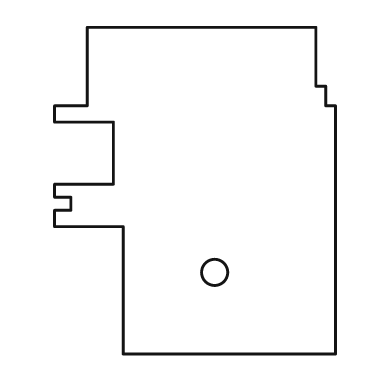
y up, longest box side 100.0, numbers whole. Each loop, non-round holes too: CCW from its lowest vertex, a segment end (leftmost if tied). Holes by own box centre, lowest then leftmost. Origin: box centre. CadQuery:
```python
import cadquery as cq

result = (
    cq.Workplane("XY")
    .moveTo(-22.0, -50.0)
    .lineTo(43.0, -50.0)
    .lineTo(43.0, 26.0)
    .lineTo(40.0, 26.0)
    .lineTo(40.0, 32.0)
    .lineTo(37.0, 32.0)
    .lineTo(37.0, 50.0)
    .lineTo(-33.0, 50.0)
    .lineTo(-33.0, 26.0)
    .lineTo(-43.0, 26.0)
    .lineTo(-43.0, 21.0)
    .lineTo(-25.0, 21.0)
    .lineTo(-25.0, 2.0)
    .lineTo(-43.0, 2.0)
    .lineTo(-43.0, -2.0)
    .lineTo(-38.0, -2.0)
    .lineTo(-38.0, -6.0)
    .lineTo(-43.0, -6.0)
    .lineTo(-43.0, -11.0)
    .lineTo(-22.0, -11.0)
    .close()
    .moveTo(6.0, -25.0)
    .circle(4.0)
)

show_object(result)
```